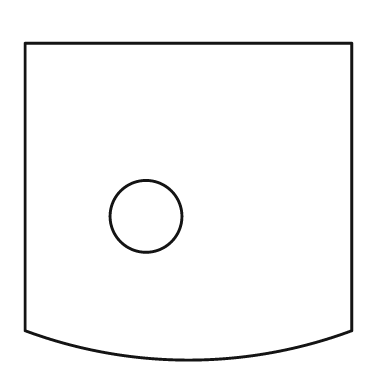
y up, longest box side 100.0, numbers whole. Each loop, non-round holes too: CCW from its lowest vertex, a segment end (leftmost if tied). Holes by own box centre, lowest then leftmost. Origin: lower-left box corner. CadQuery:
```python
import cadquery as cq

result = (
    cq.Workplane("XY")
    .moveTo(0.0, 9.0)
    .threePointArc((50.0, 0.0), (100.0, 9.0))
    .lineTo(100.0, 97.0)
    .lineTo(0.0, 97.0)
    .close()
    .moveTo(37.0, 44.0)
    .circle(11.0)
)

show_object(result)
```